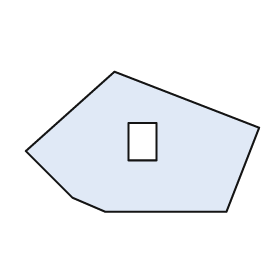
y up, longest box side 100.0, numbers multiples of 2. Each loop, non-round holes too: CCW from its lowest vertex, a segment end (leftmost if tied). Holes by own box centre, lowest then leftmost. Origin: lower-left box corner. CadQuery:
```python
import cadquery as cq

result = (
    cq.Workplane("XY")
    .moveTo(34.0, 0.0)
    .lineTo(86.0, 0.0)
    .lineTo(100.0, 36.0)
    .lineTo(38.0, 60.0)
    .lineTo(0.0, 26.0)
    .lineTo(20.0, 6.0)
    .close()
    .moveTo(44.0, 22.0)
    .lineTo(56.0, 22.0)
    .lineTo(56.0, 38.0)
    .lineTo(44.0, 38.0)
    .close()
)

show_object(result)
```